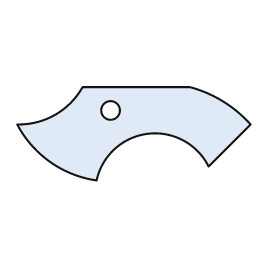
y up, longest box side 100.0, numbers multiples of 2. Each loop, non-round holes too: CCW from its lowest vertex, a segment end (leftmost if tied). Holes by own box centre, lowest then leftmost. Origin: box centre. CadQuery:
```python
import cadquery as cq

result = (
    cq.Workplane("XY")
    .moveTo(-16.0, -20.0)
    .threePointArc((6.0, 0.0), (32.0, -14.0))
    .lineTo(50.0, 4.0)
    .threePointArc((38.0, 14.0), (24.0, 20.0))
    .lineTo(-22.0, 20.0)
    .threePointArc((-34.0, 8.0), (-50.0, 4.0))
    .threePointArc((-36.0, -12.0), (-16.0, -20.0))
    .close()
    .moveTo(-10.0, 10.0)
    .circle(4.0)
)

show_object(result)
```